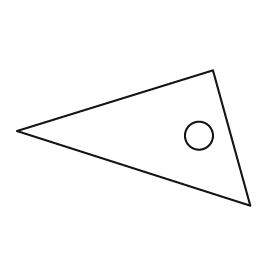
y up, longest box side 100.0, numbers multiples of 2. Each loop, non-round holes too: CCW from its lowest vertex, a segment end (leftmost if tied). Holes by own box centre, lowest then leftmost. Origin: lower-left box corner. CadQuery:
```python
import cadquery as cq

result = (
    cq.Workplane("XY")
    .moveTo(100.0, 0.0)
    .lineTo(84.0, 58.0)
    .lineTo(0.0, 32.0)
    .close()
    .moveTo(78.0, 30.0)
    .circle(6.0)
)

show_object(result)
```